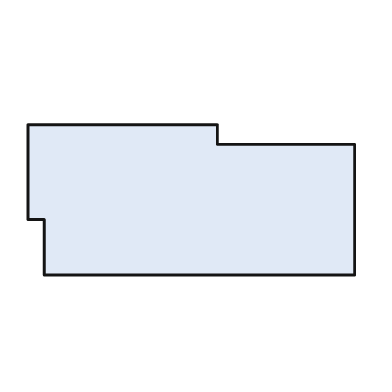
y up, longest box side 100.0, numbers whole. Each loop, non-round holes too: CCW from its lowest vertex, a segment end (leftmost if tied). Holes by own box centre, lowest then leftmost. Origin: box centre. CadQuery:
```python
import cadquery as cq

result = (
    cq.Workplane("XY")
    .moveTo(-45.0, -23.0)
    .lineTo(50.0, -23.0)
    .lineTo(50.0, 17.0)
    .lineTo(8.0, 17.0)
    .lineTo(8.0, 23.0)
    .lineTo(-50.0, 23.0)
    .lineTo(-50.0, -6.0)
    .lineTo(-45.0, -6.0)
    .close()
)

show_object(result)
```